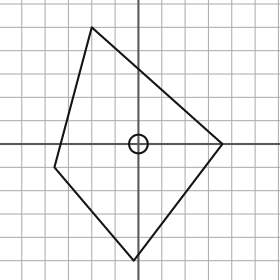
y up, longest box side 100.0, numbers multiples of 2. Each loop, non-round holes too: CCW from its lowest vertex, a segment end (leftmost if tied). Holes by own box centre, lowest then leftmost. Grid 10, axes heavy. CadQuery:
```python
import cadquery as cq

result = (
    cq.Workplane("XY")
    .moveTo(-2.0, -50.0)
    .lineTo(36.0, 0.0)
    .lineTo(-20.0, 50.0)
    .lineTo(-36.0, -10.0)
    .close()
    .moveTo(0.0, 0.0)
    .circle(4.0)
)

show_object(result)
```